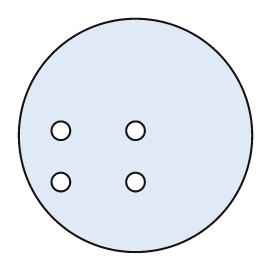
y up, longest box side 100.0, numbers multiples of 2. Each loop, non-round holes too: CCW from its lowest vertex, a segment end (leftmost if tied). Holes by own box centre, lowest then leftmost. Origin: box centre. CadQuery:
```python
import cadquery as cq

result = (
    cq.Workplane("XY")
    .moveTo(0.0, 0.0)
    .circle(50.0)
    .moveTo(-32.0, -20.0)
    .circle(4.0)
    .moveTo(0.0, -20.0)
    .circle(4.0)
    .moveTo(-32.0, 2.0)
    .circle(4.0)
    .moveTo(0.0, 2.0)
    .circle(4.0)
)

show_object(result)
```